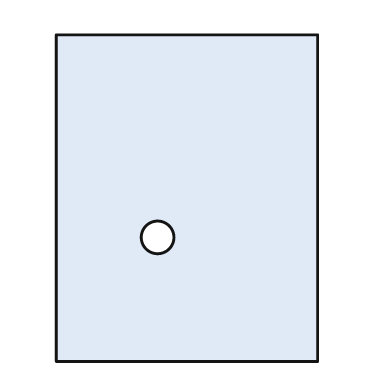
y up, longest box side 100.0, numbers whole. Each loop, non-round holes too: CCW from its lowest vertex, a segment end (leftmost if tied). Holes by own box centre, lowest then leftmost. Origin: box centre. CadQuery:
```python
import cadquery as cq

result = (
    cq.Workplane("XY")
    .moveTo(-40.0, -50.0)
    .lineTo(40.0, -50.0)
    .lineTo(40.0, 50.0)
    .lineTo(-40.0, 50.0)
    .close()
    .moveTo(-9.0, -12.0)
    .circle(5.0)
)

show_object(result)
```